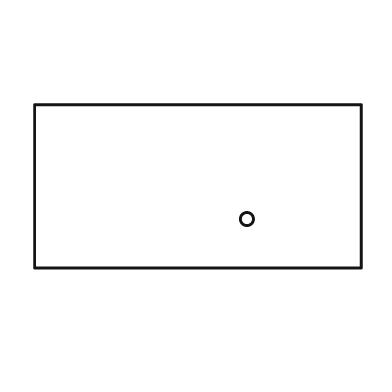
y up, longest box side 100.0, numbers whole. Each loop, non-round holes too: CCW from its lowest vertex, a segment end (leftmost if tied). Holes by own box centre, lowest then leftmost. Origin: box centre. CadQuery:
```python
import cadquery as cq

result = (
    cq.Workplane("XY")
    .moveTo(-50.0, -25.0)
    .lineTo(50.0, -25.0)
    .lineTo(50.0, 25.0)
    .lineTo(-50.0, 25.0)
    .close()
    .moveTo(15.0, -10.0)
    .circle(2.0)
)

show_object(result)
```